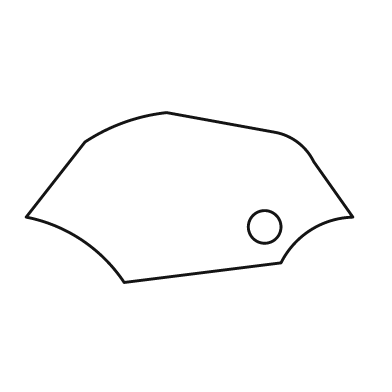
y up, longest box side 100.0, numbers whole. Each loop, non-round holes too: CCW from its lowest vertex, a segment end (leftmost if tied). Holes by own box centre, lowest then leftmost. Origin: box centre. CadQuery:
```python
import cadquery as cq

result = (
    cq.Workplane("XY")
    .moveTo(-20.0, -26.0)
    .lineTo(28.0, -20.0)
    .threePointArc((37.0, -10.0), (50.0, -6.0))
    .lineTo(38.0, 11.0)
    .threePointArc((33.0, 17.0), (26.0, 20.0))
    .lineTo(-7.0, 26.0)
    .threePointArc((-20.0, 23.0), (-32.0, 17.0))
    .lineTo(-50.0, -6.0)
    .threePointArc((-33.0, -13.0), (-20.0, -26.0))
    .close()
    .moveTo(23.0, -9.0)
    .circle(5.0)
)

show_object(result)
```